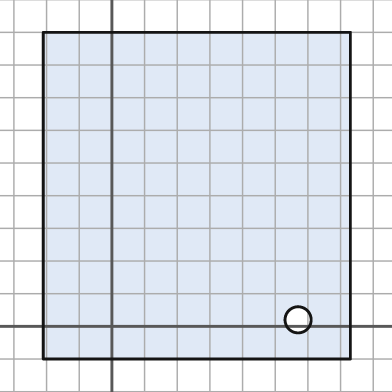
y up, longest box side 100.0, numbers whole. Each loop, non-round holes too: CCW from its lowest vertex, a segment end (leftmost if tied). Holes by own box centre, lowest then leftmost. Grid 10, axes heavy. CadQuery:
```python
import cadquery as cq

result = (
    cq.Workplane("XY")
    .moveTo(-21.0, -10.0)
    .lineTo(73.0, -10.0)
    .lineTo(73.0, 90.0)
    .lineTo(-21.0, 90.0)
    .close()
    .moveTo(57.0, 2.0)
    .circle(4.0)
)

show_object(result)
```